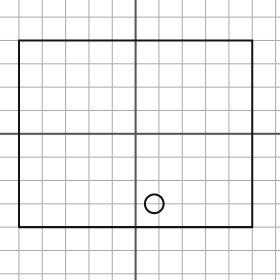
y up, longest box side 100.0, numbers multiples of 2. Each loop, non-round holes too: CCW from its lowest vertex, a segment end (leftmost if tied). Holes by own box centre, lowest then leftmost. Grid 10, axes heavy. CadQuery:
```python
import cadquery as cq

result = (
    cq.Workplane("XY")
    .moveTo(-50.0, -40.0)
    .lineTo(50.0, -40.0)
    .lineTo(50.0, 40.0)
    .lineTo(-50.0, 40.0)
    .close()
    .moveTo(8.0, -30.0)
    .circle(4.0)
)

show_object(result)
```